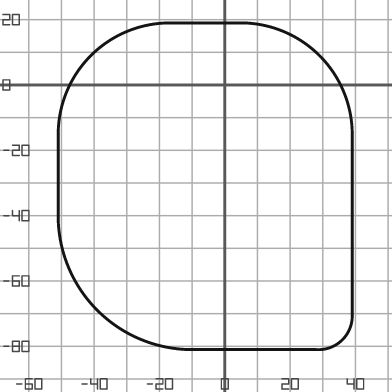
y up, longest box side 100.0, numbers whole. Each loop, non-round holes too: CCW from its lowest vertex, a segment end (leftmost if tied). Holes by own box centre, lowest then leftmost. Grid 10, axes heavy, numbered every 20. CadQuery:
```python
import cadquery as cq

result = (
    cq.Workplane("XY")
    .moveTo(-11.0, -81.0)
    .lineTo(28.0, -81.0)
    .threePointArc((36.0, -78.0), (39.0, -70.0))
    .lineTo(39.0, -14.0)
    .threePointArc((29.0, 9.0), (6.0, 19.0))
    .lineTo(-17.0, 19.0)
    .threePointArc((-41.0, 9.0), (-51.0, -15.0))
    .lineTo(-51.0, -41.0)
    .threePointArc((-39.0, -69.0), (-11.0, -81.0))
    .close()
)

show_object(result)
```